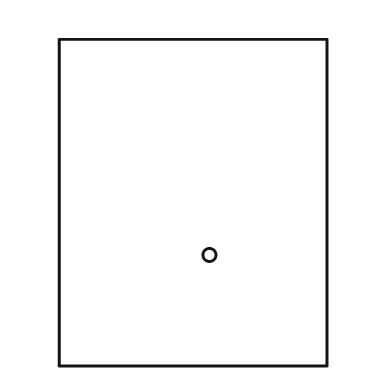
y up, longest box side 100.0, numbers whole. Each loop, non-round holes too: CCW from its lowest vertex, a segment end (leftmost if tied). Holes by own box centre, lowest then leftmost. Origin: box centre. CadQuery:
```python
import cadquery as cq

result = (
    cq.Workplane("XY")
    .moveTo(-41.0, -50.0)
    .lineTo(41.0, -50.0)
    .lineTo(41.0, 50.0)
    .lineTo(-41.0, 50.0)
    .close()
    .moveTo(5.0, -16.0)
    .circle(2.0)
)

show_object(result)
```